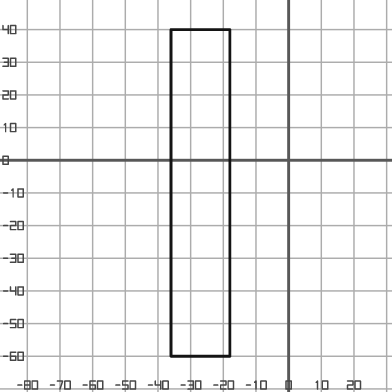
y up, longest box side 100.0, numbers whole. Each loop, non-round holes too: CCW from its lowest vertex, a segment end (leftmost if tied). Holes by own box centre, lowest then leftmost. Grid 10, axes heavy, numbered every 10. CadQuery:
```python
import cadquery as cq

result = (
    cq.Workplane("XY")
    .moveTo(-36.0, -60.0)
    .lineTo(-18.0, -60.0)
    .lineTo(-18.0, 40.0)
    .lineTo(-36.0, 40.0)
    .close()
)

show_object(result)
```